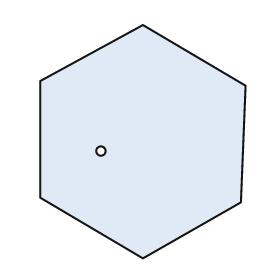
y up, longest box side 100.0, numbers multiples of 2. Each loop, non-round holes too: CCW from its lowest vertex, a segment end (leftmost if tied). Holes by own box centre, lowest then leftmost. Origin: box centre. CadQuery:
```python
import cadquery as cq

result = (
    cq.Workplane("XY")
    .moveTo(0.0, -50.0)
    .lineTo(42.0, -26.0)
    .lineTo(44.0, 24.0)
    .lineTo(0.0, 50.0)
    .lineTo(-44.0, 26.0)
    .lineTo(-44.0, -24.0)
    .close()
    .moveTo(-18.0, -4.0)
    .circle(2.0)
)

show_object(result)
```